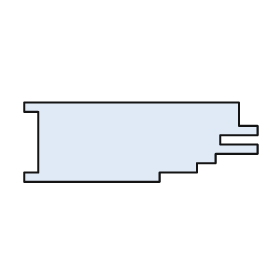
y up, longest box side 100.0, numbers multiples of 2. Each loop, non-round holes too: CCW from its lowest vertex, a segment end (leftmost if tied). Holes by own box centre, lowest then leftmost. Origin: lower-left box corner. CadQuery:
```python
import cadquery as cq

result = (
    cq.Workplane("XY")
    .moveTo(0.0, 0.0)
    .lineTo(58.0, 0.0)
    .lineTo(58.0, 4.0)
    .lineTo(74.0, 4.0)
    .lineTo(74.0, 8.0)
    .lineTo(82.0, 8.0)
    .lineTo(82.0, 12.0)
    .lineTo(100.0, 12.0)
    .lineTo(100.0, 16.0)
    .lineTo(84.0, 16.0)
    .lineTo(84.0, 20.0)
    .lineTo(100.0, 20.0)
    .lineTo(100.0, 24.0)
    .lineTo(92.0, 24.0)
    .lineTo(92.0, 34.0)
    .lineTo(0.0, 34.0)
    .lineTo(0.0, 30.0)
    .lineTo(6.0, 30.0)
    .lineTo(6.0, 4.0)
    .lineTo(0.0, 4.0)
    .close()
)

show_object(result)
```